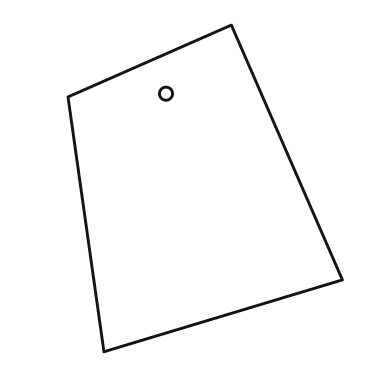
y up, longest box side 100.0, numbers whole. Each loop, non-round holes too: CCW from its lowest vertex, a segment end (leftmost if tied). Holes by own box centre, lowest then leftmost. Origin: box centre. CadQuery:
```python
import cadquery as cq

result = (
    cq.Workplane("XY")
    .moveTo(-31.0, -50.0)
    .lineTo(42.0, -28.0)
    .lineTo(8.0, 50.0)
    .lineTo(-42.0, 28.0)
    .close()
    .moveTo(-12.0, 29.0)
    .circle(2.0)
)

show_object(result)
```